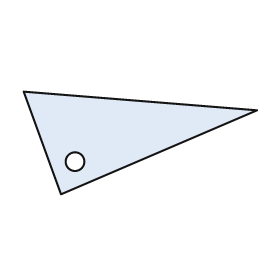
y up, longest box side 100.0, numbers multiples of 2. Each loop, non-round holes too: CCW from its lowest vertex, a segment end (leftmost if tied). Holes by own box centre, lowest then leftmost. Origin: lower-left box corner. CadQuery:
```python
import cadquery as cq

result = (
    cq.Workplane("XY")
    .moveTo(16.0, 0.0)
    .lineTo(100.0, 36.0)
    .lineTo(0.0, 44.0)
    .close()
    .moveTo(22.0, 14.0)
    .circle(4.0)
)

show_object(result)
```